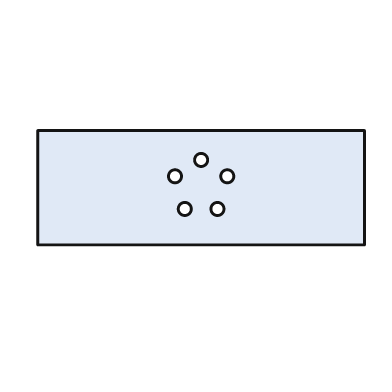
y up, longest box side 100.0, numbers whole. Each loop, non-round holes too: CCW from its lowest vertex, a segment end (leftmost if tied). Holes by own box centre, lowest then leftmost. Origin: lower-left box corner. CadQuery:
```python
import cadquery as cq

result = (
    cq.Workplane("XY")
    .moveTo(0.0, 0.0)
    .lineTo(100.0, 0.0)
    .lineTo(100.0, 35.0)
    .lineTo(0.0, 35.0)
    .close()
    .moveTo(45.0, 11.0)
    .circle(2.0)
    .moveTo(55.0, 11.0)
    .circle(2.0)
    .moveTo(42.0, 21.0)
    .circle(2.0)
    .moveTo(58.0, 21.0)
    .circle(2.0)
    .moveTo(50.0, 26.0)
    .circle(2.0)
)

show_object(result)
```